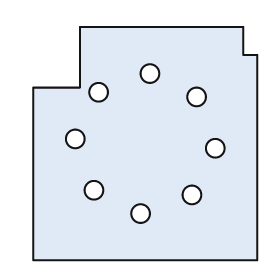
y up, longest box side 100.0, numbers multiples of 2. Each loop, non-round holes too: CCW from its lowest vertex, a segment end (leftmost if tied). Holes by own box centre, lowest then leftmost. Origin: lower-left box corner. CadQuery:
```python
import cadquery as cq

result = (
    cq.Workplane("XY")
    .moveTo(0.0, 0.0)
    .lineTo(96.0, 0.0)
    .lineTo(96.0, 88.0)
    .lineTo(90.0, 88.0)
    .lineTo(90.0, 100.0)
    .lineTo(20.0, 100.0)
    .lineTo(20.0, 74.0)
    .lineTo(0.0, 74.0)
    .close()
    .moveTo(46.0, 20.0)
    .circle(4.0)
    .moveTo(68.0, 28.0)
    .circle(4.0)
    .moveTo(26.0, 30.0)
    .circle(4.0)
    .moveTo(78.0, 48.0)
    .circle(4.0)
    .moveTo(18.0, 52.0)
    .circle(4.0)
    .moveTo(70.0, 70.0)
    .circle(4.0)
    .moveTo(28.0, 72.0)
    .circle(4.0)
    .moveTo(50.0, 80.0)
    .circle(4.0)
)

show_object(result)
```